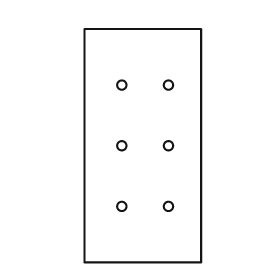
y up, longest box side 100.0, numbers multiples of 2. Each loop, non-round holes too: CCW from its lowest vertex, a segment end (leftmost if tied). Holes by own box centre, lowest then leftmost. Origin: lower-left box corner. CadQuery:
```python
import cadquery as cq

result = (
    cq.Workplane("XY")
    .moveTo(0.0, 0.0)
    .lineTo(50.0, 0.0)
    .lineTo(50.0, 100.0)
    .lineTo(0.0, 100.0)
    .close()
    .moveTo(16.0, 24.0)
    .circle(2.0)
    .moveTo(36.0, 24.0)
    .circle(2.0)
    .moveTo(16.0, 50.0)
    .circle(2.0)
    .moveTo(36.0, 50.0)
    .circle(2.0)
    .moveTo(16.0, 76.0)
    .circle(2.0)
    .moveTo(36.0, 76.0)
    .circle(2.0)
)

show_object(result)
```